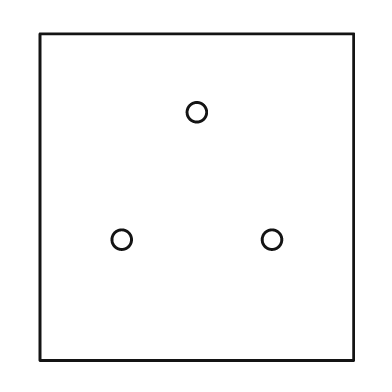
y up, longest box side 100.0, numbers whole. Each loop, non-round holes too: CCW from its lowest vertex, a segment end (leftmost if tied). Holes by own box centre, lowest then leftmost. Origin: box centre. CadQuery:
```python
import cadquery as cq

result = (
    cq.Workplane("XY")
    .moveTo(-48.0, -50.0)
    .lineTo(48.0, -50.0)
    .lineTo(48.0, 50.0)
    .lineTo(-48.0, 50.0)
    .close()
    .moveTo(-23.0, -13.0)
    .circle(3.0)
    .moveTo(23.0, -13.0)
    .circle(3.0)
    .moveTo(0.0, 26.0)
    .circle(3.0)
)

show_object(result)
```